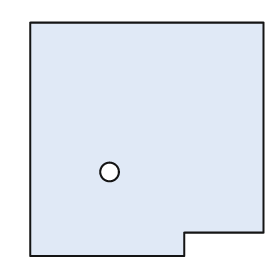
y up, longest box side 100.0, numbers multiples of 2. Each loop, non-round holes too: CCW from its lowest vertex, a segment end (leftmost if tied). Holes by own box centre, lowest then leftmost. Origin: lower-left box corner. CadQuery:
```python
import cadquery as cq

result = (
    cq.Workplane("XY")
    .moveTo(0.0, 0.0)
    .lineTo(66.0, 0.0)
    .lineTo(66.0, 10.0)
    .lineTo(100.0, 10.0)
    .lineTo(100.0, 100.0)
    .lineTo(0.0, 100.0)
    .close()
    .moveTo(34.0, 36.0)
    .circle(4.0)
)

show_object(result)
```